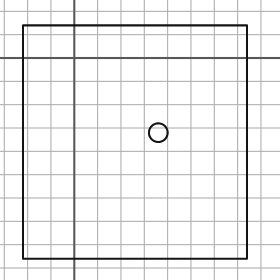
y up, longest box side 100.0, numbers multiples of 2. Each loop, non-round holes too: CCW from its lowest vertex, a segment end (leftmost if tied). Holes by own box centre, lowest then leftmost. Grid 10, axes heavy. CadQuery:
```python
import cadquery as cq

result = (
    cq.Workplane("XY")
    .moveTo(-22.0, -86.0)
    .lineTo(74.0, -86.0)
    .lineTo(74.0, 14.0)
    .lineTo(-22.0, 14.0)
    .close()
    .moveTo(36.0, -32.0)
    .circle(4.0)
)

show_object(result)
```